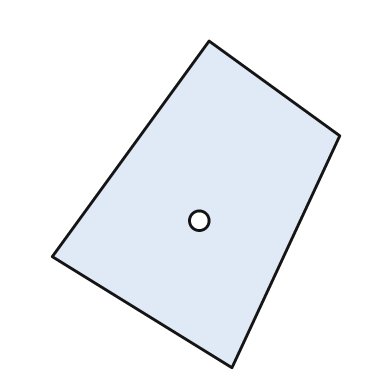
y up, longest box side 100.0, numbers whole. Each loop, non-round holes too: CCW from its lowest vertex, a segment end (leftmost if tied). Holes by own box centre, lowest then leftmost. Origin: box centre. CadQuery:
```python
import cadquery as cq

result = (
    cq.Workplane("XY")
    .moveTo(11.0, -50.0)
    .lineTo(44.0, 21.0)
    .lineTo(4.0, 50.0)
    .lineTo(-44.0, -16.0)
    .close()
    .moveTo(1.0, -5.0)
    .circle(3.0)
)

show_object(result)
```